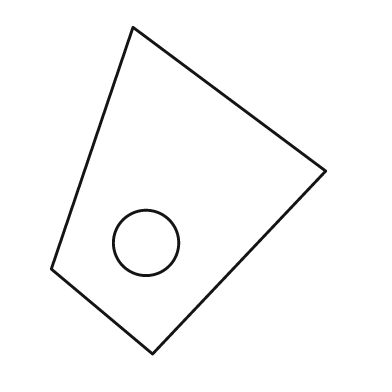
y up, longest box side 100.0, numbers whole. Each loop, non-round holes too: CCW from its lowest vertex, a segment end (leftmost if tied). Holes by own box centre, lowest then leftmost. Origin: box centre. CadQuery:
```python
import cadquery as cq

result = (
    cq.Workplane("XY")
    .moveTo(-11.0, -50.0)
    .lineTo(42.0, 6.0)
    .lineTo(-17.0, 50.0)
    .lineTo(-42.0, -24.0)
    .close()
    .moveTo(-13.0, -16.0)
    .circle(10.0)
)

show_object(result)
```